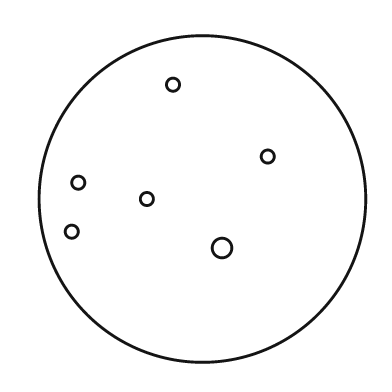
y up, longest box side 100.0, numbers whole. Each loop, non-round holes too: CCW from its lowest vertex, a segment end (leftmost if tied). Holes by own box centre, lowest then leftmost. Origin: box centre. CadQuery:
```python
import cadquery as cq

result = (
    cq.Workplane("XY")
    .moveTo(0.0, 0.0)
    .circle(50.0)
    .moveTo(6.0, -15.0)
    .circle(3.0)
    .moveTo(-40.0, -10.0)
    .circle(2.0)
    .moveTo(-17.0, 0.0)
    .circle(2.0)
    .moveTo(-38.0, 5.0)
    .circle(2.0)
    .moveTo(20.0, 13.0)
    .circle(2.0)
    .moveTo(-9.0, 35.0)
    .circle(2.0)
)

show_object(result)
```